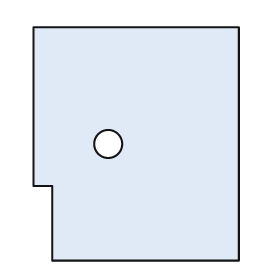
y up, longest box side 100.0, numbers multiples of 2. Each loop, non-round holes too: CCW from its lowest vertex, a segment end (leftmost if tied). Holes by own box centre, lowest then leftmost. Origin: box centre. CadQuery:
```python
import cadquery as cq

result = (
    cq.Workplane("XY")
    .moveTo(-36.0, -50.0)
    .lineTo(44.0, -50.0)
    .lineTo(44.0, 50.0)
    .lineTo(-44.0, 50.0)
    .lineTo(-44.0, -18.0)
    .lineTo(-36.0, -18.0)
    .close()
    .moveTo(-12.0, 0.0)
    .circle(6.0)
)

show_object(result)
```